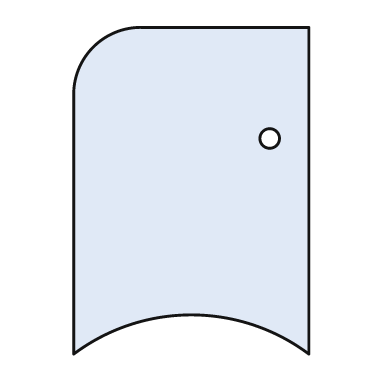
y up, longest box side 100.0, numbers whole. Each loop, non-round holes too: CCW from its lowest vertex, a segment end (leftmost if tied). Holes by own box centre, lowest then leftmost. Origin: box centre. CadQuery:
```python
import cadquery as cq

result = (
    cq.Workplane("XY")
    .moveTo(-36.0, -50.0)
    .threePointArc((0.0, -38.0), (36.0, -50.0))
    .lineTo(36.0, 50.0)
    .lineTo(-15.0, 50.0)
    .threePointArc((-30.0, 44.0), (-36.0, 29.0))
    .close()
    .moveTo(24.0, 16.0)
    .circle(3.0)
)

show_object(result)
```